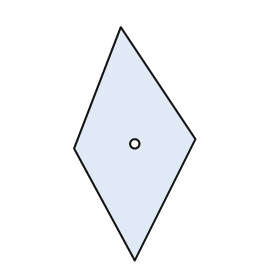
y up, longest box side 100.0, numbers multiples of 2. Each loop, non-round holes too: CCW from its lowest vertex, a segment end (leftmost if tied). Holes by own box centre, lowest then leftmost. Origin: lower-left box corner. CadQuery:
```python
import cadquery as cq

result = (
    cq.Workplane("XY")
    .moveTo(26.0, 0.0)
    .lineTo(52.0, 52.0)
    .lineTo(20.0, 100.0)
    .lineTo(0.0, 48.0)
    .close()
    .moveTo(26.0, 50.0)
    .circle(2.0)
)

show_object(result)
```